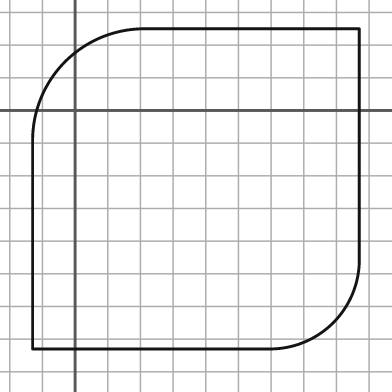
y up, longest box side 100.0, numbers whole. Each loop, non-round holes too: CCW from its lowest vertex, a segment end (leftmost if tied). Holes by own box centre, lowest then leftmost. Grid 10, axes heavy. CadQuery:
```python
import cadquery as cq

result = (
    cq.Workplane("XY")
    .moveTo(-13.0, -73.0)
    .lineTo(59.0, -73.0)
    .threePointArc((79.0, -65.0), (87.0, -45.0))
    .lineTo(87.0, 25.0)
    .lineTo(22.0, 25.0)
    .threePointArc((-3.0, 15.0), (-13.0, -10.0))
    .close()
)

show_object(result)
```